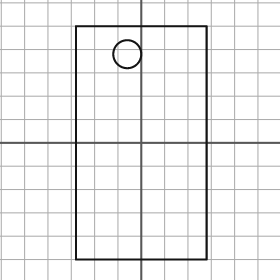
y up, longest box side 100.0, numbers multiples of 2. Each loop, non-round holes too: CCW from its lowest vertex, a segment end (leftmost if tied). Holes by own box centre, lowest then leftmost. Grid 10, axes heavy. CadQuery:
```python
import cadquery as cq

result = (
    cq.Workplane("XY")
    .moveTo(-28.0, -50.0)
    .lineTo(28.0, -50.0)
    .lineTo(28.0, 50.0)
    .lineTo(-28.0, 50.0)
    .close()
    .moveTo(-6.0, 38.0)
    .circle(6.0)
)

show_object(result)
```